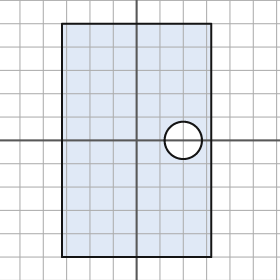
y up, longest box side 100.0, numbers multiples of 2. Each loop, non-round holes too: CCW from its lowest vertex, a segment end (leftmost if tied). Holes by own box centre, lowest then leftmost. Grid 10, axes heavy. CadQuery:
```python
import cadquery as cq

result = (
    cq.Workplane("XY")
    .moveTo(-32.0, -50.0)
    .lineTo(32.0, -50.0)
    .lineTo(32.0, 50.0)
    .lineTo(-32.0, 50.0)
    .close()
    .moveTo(20.0, 0.0)
    .circle(8.0)
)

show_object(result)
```